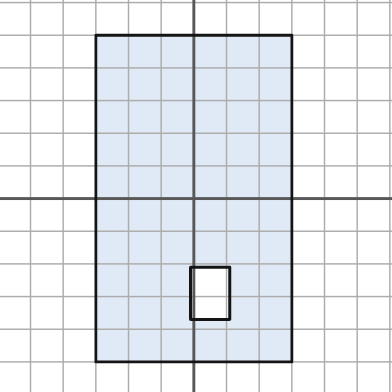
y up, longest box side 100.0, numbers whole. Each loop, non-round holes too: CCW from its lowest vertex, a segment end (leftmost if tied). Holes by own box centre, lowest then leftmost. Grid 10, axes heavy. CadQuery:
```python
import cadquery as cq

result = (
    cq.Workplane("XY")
    .moveTo(-30.0, -50.0)
    .lineTo(30.0, -50.0)
    .lineTo(30.0, 50.0)
    .lineTo(-30.0, 50.0)
    .close()
    .moveTo(-1.0, -37.0)
    .lineTo(11.0, -37.0)
    .lineTo(11.0, -21.0)
    .lineTo(-1.0, -21.0)
    .close()
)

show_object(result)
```